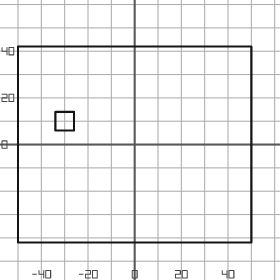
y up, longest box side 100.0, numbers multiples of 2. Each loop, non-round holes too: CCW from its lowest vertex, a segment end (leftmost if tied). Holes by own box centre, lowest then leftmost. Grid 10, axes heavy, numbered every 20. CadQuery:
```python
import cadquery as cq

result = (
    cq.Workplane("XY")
    .moveTo(-50.0, -42.0)
    .lineTo(50.0, -42.0)
    .lineTo(50.0, 42.0)
    .lineTo(-50.0, 42.0)
    .close()
    .moveTo(-34.0, 6.0)
    .lineTo(-26.0, 6.0)
    .lineTo(-26.0, 14.0)
    .lineTo(-34.0, 14.0)
    .close()
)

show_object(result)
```